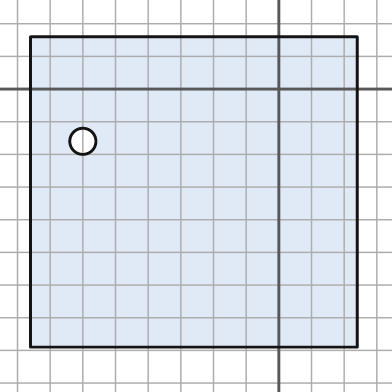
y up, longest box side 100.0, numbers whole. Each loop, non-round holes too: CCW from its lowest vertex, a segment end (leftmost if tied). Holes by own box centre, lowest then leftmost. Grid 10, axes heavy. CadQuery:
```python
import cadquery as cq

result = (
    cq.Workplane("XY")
    .moveTo(-76.0, -79.0)
    .lineTo(24.0, -79.0)
    .lineTo(24.0, 16.0)
    .lineTo(-76.0, 16.0)
    .close()
    .moveTo(-60.0, -16.0)
    .circle(4.0)
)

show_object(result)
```